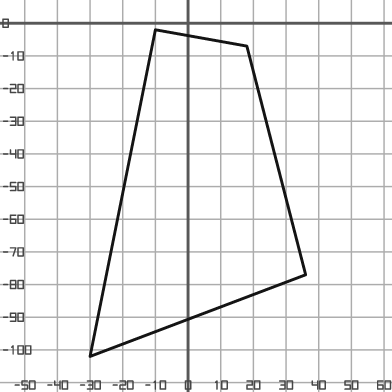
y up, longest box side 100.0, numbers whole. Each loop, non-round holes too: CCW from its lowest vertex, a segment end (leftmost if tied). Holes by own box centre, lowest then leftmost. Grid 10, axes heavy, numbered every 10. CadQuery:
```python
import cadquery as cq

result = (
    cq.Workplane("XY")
    .moveTo(-30.0, -102.0)
    .lineTo(36.0, -77.0)
    .lineTo(18.0, -7.0)
    .lineTo(-10.0, -2.0)
    .close()
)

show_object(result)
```